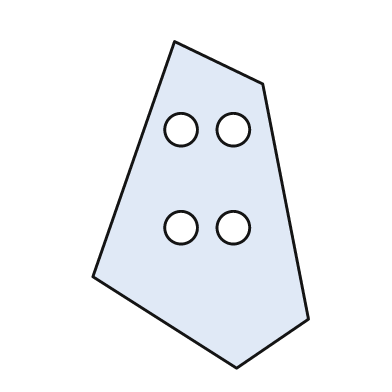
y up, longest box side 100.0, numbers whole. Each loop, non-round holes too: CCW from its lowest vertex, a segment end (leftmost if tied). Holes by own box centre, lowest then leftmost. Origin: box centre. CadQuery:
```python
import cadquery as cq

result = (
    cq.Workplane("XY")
    .moveTo(11.0, -50.0)
    .lineTo(33.0, -35.0)
    .lineTo(19.0, 37.0)
    .lineTo(-8.0, 50.0)
    .lineTo(-33.0, -22.0)
    .close()
    .moveTo(-6.0, -7.0)
    .circle(5.0)
    .moveTo(10.0, -7.0)
    .circle(5.0)
    .moveTo(-6.0, 23.0)
    .circle(5.0)
    .moveTo(10.0, 23.0)
    .circle(5.0)
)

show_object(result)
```